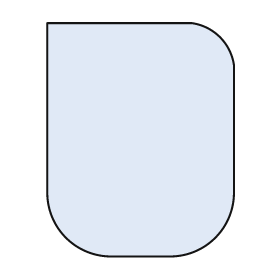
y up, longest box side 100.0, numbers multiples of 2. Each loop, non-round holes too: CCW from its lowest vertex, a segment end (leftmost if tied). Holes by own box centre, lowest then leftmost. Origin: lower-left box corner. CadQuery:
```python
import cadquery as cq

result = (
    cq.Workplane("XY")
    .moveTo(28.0, 0.0)
    .lineTo(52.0, 0.0)
    .threePointArc((72.0, 8.0), (80.0, 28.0))
    .lineTo(80.0, 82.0)
    .threePointArc((74.0, 94.0), (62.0, 100.0))
    .lineTo(0.0, 100.0)
    .lineTo(0.0, 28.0)
    .threePointArc((8.0, 8.0), (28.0, 0.0))
    .close()
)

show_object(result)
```